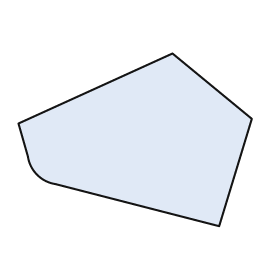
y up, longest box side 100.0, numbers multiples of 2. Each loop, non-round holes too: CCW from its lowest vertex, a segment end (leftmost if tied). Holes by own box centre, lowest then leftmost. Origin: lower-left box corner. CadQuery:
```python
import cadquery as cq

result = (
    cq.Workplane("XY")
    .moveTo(86.0, 0.0)
    .lineTo(100.0, 46.0)
    .lineTo(66.0, 74.0)
    .lineTo(0.0, 44.0)
    .lineTo(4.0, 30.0)
    .threePointArc((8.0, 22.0), (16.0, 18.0))
    .close()
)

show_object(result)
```